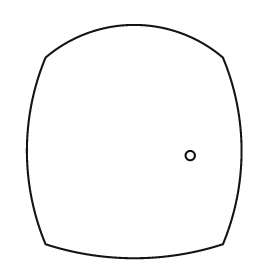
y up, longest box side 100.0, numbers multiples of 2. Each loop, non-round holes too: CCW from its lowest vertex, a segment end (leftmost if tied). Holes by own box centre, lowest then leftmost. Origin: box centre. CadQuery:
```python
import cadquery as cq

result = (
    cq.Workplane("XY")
    .moveTo(-38.0, -44.0)
    .threePointArc((0.0, -50.0), (38.0, -44.0))
    .threePointArc((46.0, -4.0), (38.0, 36.0))
    .threePointArc((0.0, 50.0), (-38.0, 36.0))
    .threePointArc((-46.0, -4.0), (-38.0, -44.0))
    .close()
    .moveTo(24.0, -6.0)
    .circle(2.0)
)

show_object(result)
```